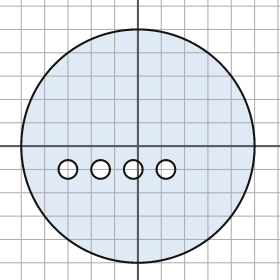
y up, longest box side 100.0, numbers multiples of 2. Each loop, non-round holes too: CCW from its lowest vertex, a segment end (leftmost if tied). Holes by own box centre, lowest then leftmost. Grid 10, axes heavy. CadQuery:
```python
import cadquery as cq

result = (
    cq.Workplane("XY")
    .moveTo(0.0, 0.0)
    .circle(50.0)
    .moveTo(-30.0, -10.0)
    .circle(4.0)
    .moveTo(-16.0, -10.0)
    .circle(4.0)
    .moveTo(-2.0, -10.0)
    .circle(4.0)
    .moveTo(12.0, -10.0)
    .circle(4.0)
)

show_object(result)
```